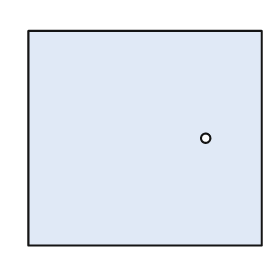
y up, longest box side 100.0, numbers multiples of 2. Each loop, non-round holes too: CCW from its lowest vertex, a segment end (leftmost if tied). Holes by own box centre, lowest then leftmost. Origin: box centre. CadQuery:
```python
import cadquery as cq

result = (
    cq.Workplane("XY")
    .moveTo(-50.0, -46.0)
    .lineTo(50.0, -46.0)
    .lineTo(50.0, 46.0)
    .lineTo(-50.0, 46.0)
    .close()
    .moveTo(26.0, 0.0)
    .circle(2.0)
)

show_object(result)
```